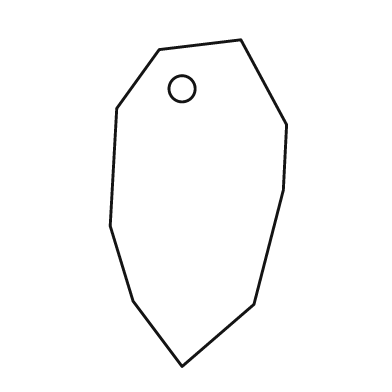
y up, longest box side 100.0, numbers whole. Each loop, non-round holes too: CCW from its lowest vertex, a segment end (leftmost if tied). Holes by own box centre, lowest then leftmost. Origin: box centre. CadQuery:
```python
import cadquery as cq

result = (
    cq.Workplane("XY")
    .moveTo(-5.0, -50.0)
    .lineTo(17.0, -31.0)
    .lineTo(26.0, 4.0)
    .lineTo(27.0, 24.0)
    .lineTo(13.0, 50.0)
    .lineTo(-12.0, 47.0)
    .lineTo(-25.0, 29.0)
    .lineTo(-27.0, -7.0)
    .lineTo(-20.0, -30.0)
    .close()
    .moveTo(-5.0, 35.0)
    .circle(4.0)
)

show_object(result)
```